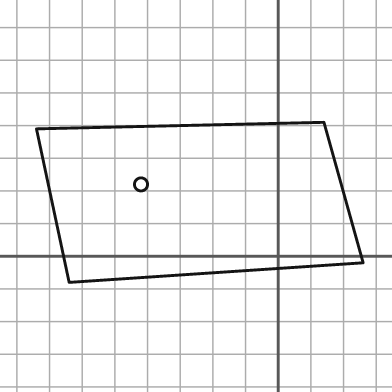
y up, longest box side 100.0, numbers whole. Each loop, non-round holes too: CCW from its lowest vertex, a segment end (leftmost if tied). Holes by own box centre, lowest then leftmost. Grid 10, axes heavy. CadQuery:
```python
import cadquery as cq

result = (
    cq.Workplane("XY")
    .moveTo(-64.0, -8.0)
    .lineTo(26.0, -2.0)
    .lineTo(14.0, 41.0)
    .lineTo(-74.0, 39.0)
    .close()
    .moveTo(-42.0, 22.0)
    .circle(2.0)
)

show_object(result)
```